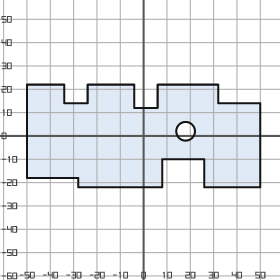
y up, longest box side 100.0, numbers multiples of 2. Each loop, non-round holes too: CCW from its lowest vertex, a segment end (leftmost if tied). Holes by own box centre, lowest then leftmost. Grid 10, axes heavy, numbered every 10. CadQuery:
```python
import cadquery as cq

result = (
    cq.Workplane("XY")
    .moveTo(-28.0, -22.0)
    .lineTo(8.0, -22.0)
    .lineTo(8.0, -10.0)
    .lineTo(26.0, -10.0)
    .lineTo(26.0, -22.0)
    .lineTo(50.0, -22.0)
    .lineTo(50.0, 14.0)
    .lineTo(32.0, 14.0)
    .lineTo(32.0, 22.0)
    .lineTo(6.0, 22.0)
    .lineTo(6.0, 12.0)
    .lineTo(-4.0, 12.0)
    .lineTo(-4.0, 22.0)
    .lineTo(-24.0, 22.0)
    .lineTo(-24.0, 14.0)
    .lineTo(-34.0, 14.0)
    .lineTo(-34.0, 22.0)
    .lineTo(-50.0, 22.0)
    .lineTo(-50.0, -18.0)
    .lineTo(-28.0, -18.0)
    .close()
    .moveTo(18.0, 2.0)
    .circle(4.0)
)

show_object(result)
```